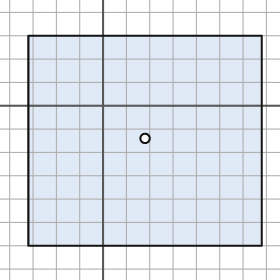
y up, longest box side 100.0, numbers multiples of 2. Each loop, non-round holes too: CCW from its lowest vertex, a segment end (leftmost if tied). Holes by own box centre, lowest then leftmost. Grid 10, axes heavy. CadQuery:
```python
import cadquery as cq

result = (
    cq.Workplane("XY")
    .moveTo(-32.0, -60.0)
    .lineTo(68.0, -60.0)
    .lineTo(68.0, 30.0)
    .lineTo(-32.0, 30.0)
    .close()
    .moveTo(18.0, -14.0)
    .circle(2.0)
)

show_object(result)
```